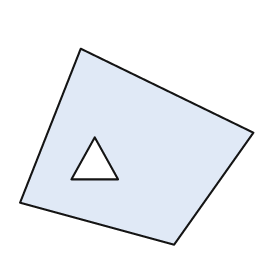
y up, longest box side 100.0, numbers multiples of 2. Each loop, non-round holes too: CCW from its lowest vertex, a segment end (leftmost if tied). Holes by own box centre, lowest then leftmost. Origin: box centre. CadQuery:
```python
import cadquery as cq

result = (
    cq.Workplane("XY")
    .moveTo(16.0, -42.0)
    .lineTo(50.0, 6.0)
    .lineTo(-24.0, 42.0)
    .lineTo(-50.0, -24.0)
    .close()
    .moveTo(-28.0, -14.0)
    .lineTo(-8.0, -14.0)
    .lineTo(-18.0, 4.0)
    .close()
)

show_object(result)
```